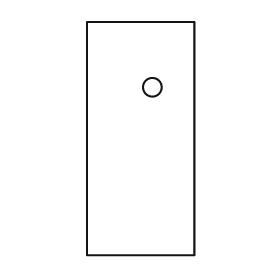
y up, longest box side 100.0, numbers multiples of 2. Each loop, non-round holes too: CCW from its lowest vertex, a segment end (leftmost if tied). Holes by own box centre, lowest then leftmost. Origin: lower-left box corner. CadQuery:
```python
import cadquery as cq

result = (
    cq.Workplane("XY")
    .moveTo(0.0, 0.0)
    .lineTo(46.0, 0.0)
    .lineTo(46.0, 100.0)
    .lineTo(0.0, 100.0)
    .close()
    .moveTo(28.0, 72.0)
    .circle(4.0)
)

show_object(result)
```